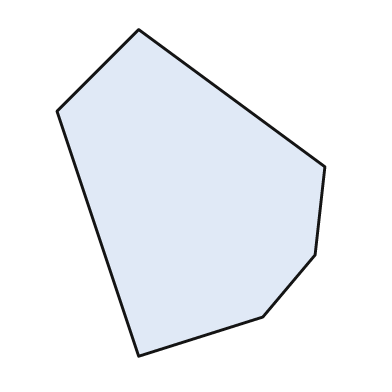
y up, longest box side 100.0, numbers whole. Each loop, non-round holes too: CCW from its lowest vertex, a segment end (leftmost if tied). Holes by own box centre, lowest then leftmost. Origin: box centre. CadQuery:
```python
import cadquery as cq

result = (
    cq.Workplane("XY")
    .moveTo(-16.0, -50.0)
    .lineTo(22.0, -38.0)
    .lineTo(38.0, -19.0)
    .lineTo(41.0, 8.0)
    .lineTo(-16.0, 50.0)
    .lineTo(-41.0, 25.0)
    .close()
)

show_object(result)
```